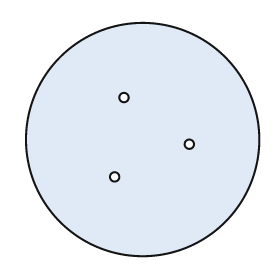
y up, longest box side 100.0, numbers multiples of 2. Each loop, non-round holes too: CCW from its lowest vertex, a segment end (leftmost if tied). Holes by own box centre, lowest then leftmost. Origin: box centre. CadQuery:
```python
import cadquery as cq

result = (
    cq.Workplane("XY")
    .moveTo(0.0, 0.0)
    .circle(50.0)
    .moveTo(-12.0, -16.0)
    .circle(2.0)
    .moveTo(20.0, -2.0)
    .circle(2.0)
    .moveTo(-8.0, 18.0)
    .circle(2.0)
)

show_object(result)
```